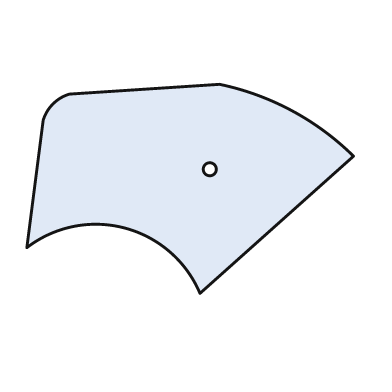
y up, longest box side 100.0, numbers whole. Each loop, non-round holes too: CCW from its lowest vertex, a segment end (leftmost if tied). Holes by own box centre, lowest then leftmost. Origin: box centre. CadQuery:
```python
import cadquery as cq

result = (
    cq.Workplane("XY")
    .moveTo(3.0, -32.0)
    .lineTo(50.0, 10.0)
    .threePointArc((31.0, 24.0), (9.0, 32.0))
    .lineTo(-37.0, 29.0)
    .threePointArc((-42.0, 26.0), (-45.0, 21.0))
    .lineTo(-50.0, -18.0)
    .threePointArc((-20.0, -12.0), (3.0, -32.0))
    .close()
    .moveTo(6.0, 6.0)
    .circle(2.0)
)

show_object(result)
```